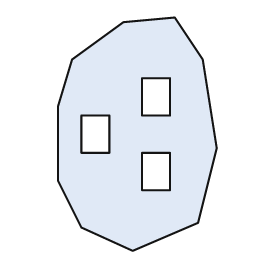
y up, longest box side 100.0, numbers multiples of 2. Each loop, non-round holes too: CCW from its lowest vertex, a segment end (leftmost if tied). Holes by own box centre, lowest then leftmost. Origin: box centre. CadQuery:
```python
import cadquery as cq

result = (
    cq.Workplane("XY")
    .moveTo(-2.0, -50.0)
    .lineTo(26.0, -38.0)
    .lineTo(34.0, -6.0)
    .lineTo(28.0, 32.0)
    .lineTo(16.0, 50.0)
    .lineTo(-6.0, 48.0)
    .lineTo(-28.0, 32.0)
    .lineTo(-34.0, 12.0)
    .lineTo(-34.0, -20.0)
    .lineTo(-24.0, -40.0)
    .close()
    .moveTo(2.0, -24.0)
    .lineTo(14.0, -24.0)
    .lineTo(14.0, -8.0)
    .lineTo(2.0, -8.0)
    .close()
    .moveTo(-24.0, -8.0)
    .lineTo(-12.0, -8.0)
    .lineTo(-12.0, 8.0)
    .lineTo(-24.0, 8.0)
    .close()
    .moveTo(2.0, 8.0)
    .lineTo(14.0, 8.0)
    .lineTo(14.0, 24.0)
    .lineTo(2.0, 24.0)
    .close()
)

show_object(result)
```